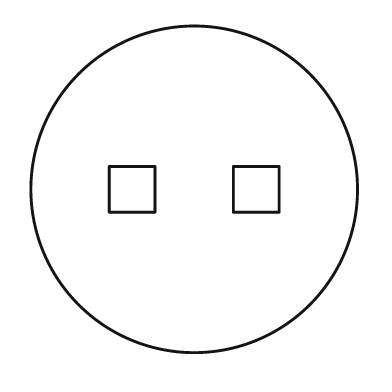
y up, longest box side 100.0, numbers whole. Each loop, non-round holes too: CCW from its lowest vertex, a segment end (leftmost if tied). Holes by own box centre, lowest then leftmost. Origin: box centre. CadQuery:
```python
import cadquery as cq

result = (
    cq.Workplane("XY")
    .moveTo(0.0, 0.0)
    .circle(50.0)
    .moveTo(-26.0, -7.0)
    .lineTo(-12.0, -7.0)
    .lineTo(-12.0, 7.0)
    .lineTo(-26.0, 7.0)
    .close()
    .moveTo(12.0, -7.0)
    .lineTo(26.0, -7.0)
    .lineTo(26.0, 7.0)
    .lineTo(12.0, 7.0)
    .close()
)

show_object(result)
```